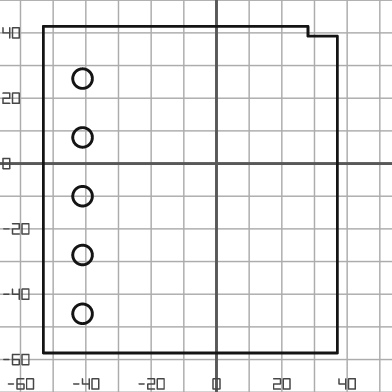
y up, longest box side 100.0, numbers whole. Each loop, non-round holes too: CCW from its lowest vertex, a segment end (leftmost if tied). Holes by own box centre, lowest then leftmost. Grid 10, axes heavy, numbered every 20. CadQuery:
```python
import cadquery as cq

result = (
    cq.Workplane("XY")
    .moveTo(-53.0, -58.0)
    .lineTo(37.0, -58.0)
    .lineTo(37.0, 39.0)
    .lineTo(28.0, 39.0)
    .lineTo(28.0, 42.0)
    .lineTo(-53.0, 42.0)
    .close()
    .moveTo(-41.0, -46.0)
    .circle(3.0)
    .moveTo(-41.0, -28.0)
    .circle(3.0)
    .moveTo(-41.0, -10.0)
    .circle(3.0)
    .moveTo(-41.0, 8.0)
    .circle(3.0)
    .moveTo(-41.0, 26.0)
    .circle(3.0)
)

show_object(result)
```